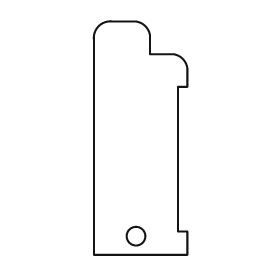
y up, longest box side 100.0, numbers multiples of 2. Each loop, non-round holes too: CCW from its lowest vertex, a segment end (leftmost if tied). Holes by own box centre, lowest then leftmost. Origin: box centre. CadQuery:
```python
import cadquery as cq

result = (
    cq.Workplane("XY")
    .moveTo(-20.0, -50.0)
    .lineTo(20.0, -50.0)
    .lineTo(20.0, -40.0)
    .lineTo(16.0, -40.0)
    .lineTo(16.0, 22.0)
    .lineTo(20.0, 22.0)
    .lineTo(20.0, 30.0)
    .threePointArc((18.0, 34.0), (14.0, 36.0))
    .lineTo(4.0, 36.0)
    .lineTo(4.0, 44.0)
    .threePointArc((2.0, 48.0), (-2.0, 50.0))
    .lineTo(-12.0, 50.0)
    .threePointArc((-18.0, 48.0), (-20.0, 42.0))
    .close()
    .moveTo(-2.0, -42.0)
    .circle(4.0)
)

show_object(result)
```